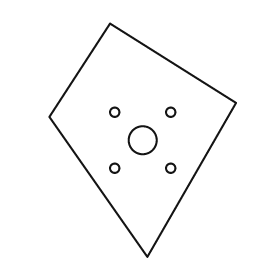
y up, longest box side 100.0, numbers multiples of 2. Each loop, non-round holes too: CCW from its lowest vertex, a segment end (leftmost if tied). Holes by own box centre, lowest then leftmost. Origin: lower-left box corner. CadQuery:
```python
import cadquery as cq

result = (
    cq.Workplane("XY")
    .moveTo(42.0, 0.0)
    .lineTo(80.0, 66.0)
    .lineTo(26.0, 100.0)
    .lineTo(0.0, 60.0)
    .close()
    .moveTo(28.0, 38.0)
    .circle(2.0)
    .moveTo(52.0, 38.0)
    .circle(2.0)
    .moveTo(40.0, 50.0)
    .circle(6.0)
    .moveTo(28.0, 62.0)
    .circle(2.0)
    .moveTo(52.0, 62.0)
    .circle(2.0)
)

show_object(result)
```